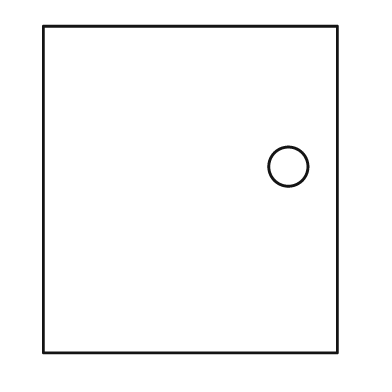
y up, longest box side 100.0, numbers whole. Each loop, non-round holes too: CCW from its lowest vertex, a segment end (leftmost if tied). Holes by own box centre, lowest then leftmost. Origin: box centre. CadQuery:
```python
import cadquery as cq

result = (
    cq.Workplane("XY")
    .moveTo(-45.0, -50.0)
    .lineTo(45.0, -50.0)
    .lineTo(45.0, 50.0)
    .lineTo(-45.0, 50.0)
    .close()
    .moveTo(30.0, 7.0)
    .circle(6.0)
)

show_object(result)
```